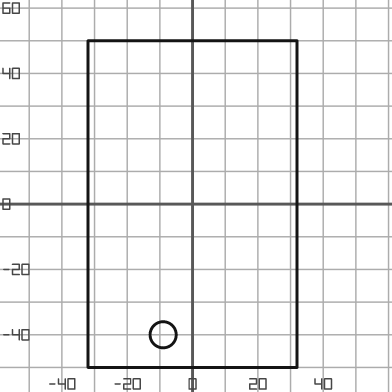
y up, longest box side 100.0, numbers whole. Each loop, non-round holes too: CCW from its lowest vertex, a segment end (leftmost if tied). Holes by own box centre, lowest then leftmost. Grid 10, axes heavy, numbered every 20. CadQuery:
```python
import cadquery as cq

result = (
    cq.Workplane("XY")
    .moveTo(-32.0, -50.0)
    .lineTo(32.0, -50.0)
    .lineTo(32.0, 50.0)
    .lineTo(-32.0, 50.0)
    .close()
    .moveTo(-9.0, -40.0)
    .circle(4.0)
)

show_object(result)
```